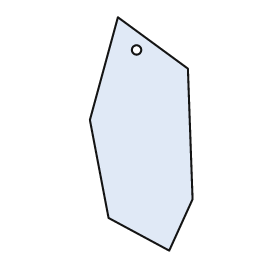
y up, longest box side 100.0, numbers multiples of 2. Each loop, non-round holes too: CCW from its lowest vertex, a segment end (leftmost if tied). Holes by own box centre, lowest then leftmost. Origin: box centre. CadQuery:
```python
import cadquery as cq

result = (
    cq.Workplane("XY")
    .moveTo(12.0, -50.0)
    .lineTo(22.0, -28.0)
    .lineTo(20.0, 28.0)
    .lineTo(-10.0, 50.0)
    .lineTo(-22.0, 6.0)
    .lineTo(-14.0, -36.0)
    .close()
    .moveTo(-2.0, 36.0)
    .circle(2.0)
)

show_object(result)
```